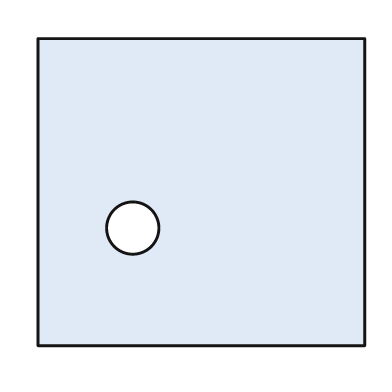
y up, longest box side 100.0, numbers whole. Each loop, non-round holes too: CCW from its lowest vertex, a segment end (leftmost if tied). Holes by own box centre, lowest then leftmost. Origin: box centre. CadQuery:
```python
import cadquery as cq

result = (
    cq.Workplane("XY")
    .moveTo(-50.0, -47.0)
    .lineTo(50.0, -47.0)
    .lineTo(50.0, 47.0)
    .lineTo(-50.0, 47.0)
    .close()
    .moveTo(-21.0, -11.0)
    .circle(8.0)
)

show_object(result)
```